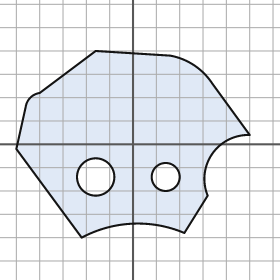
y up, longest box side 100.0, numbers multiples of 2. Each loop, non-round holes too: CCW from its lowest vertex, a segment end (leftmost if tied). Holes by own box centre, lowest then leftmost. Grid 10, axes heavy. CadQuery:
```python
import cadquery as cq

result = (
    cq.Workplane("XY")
    .moveTo(-22.0, -40.0)
    .threePointArc((0.0, -34.0), (22.0, -38.0))
    .lineTo(32.0, -22.0)
    .threePointArc((34.0, -4.0), (50.0, 4.0))
    .lineTo(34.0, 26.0)
    .threePointArc((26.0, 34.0), (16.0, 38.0))
    .lineTo(-16.0, 40.0)
    .lineTo(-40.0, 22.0)
    .threePointArc((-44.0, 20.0), (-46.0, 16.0))
    .lineTo(-50.0, -2.0)
    .close()
    .moveTo(-16.0, -14.0)
    .circle(8.0)
    .moveTo(14.0, -14.0)
    .circle(6.0)
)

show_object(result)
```